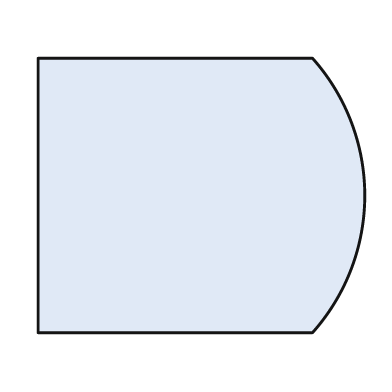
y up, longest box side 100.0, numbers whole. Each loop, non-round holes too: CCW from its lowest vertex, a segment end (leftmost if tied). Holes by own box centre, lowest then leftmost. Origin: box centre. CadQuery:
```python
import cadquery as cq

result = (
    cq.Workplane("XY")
    .moveTo(-50.0, -42.0)
    .lineTo(34.0, -42.0)
    .threePointArc((50.0, 0.0), (34.0, 42.0))
    .lineTo(-50.0, 42.0)
    .close()
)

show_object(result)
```